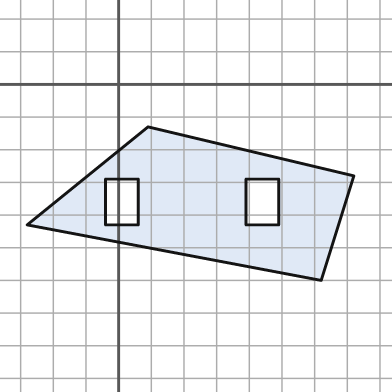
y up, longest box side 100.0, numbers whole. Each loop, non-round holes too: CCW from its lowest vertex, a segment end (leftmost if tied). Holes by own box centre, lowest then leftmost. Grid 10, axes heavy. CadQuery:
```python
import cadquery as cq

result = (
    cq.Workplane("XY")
    .moveTo(62.0, -60.0)
    .lineTo(72.0, -28.0)
    .lineTo(9.0, -13.0)
    .lineTo(-28.0, -43.0)
    .close()
    .moveTo(-4.0, -43.0)
    .lineTo(6.0, -43.0)
    .lineTo(6.0, -29.0)
    .lineTo(-4.0, -29.0)
    .close()
    .moveTo(39.0, -43.0)
    .lineTo(49.0, -43.0)
    .lineTo(49.0, -29.0)
    .lineTo(39.0, -29.0)
    .close()
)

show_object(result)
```